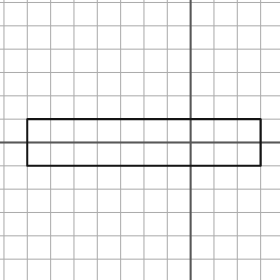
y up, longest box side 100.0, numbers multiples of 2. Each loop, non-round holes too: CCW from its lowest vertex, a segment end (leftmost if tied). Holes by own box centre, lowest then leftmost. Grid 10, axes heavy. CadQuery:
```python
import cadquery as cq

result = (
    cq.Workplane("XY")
    .moveTo(-70.0, -10.0)
    .lineTo(30.0, -10.0)
    .lineTo(30.0, 10.0)
    .lineTo(-70.0, 10.0)
    .close()
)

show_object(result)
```